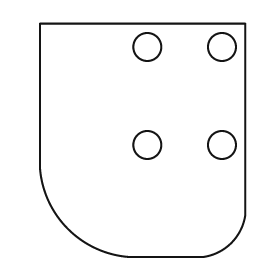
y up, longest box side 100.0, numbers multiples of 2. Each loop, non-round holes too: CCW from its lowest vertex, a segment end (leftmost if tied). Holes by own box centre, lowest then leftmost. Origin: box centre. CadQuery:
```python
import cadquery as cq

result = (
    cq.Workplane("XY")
    .moveTo(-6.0, -50.0)
    .lineTo(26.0, -50.0)
    .threePointArc((38.0, -44.0), (44.0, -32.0))
    .lineTo(44.0, 50.0)
    .lineTo(-44.0, 50.0)
    .lineTo(-44.0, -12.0)
    .threePointArc((-32.0, -38.0), (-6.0, -50.0))
    .close()
    .moveTo(2.0, -2.0)
    .circle(6.0)
    .moveTo(34.0, -2.0)
    .circle(6.0)
    .moveTo(2.0, 40.0)
    .circle(6.0)
    .moveTo(34.0, 40.0)
    .circle(6.0)
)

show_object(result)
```